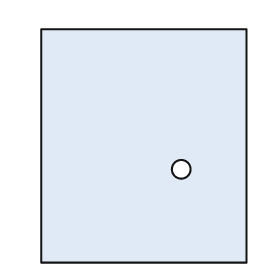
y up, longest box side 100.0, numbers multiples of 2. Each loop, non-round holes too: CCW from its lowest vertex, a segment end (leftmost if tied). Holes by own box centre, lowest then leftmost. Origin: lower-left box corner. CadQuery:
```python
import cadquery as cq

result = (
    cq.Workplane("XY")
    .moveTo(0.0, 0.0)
    .lineTo(88.0, 0.0)
    .lineTo(88.0, 100.0)
    .lineTo(0.0, 100.0)
    .close()
    .moveTo(60.0, 40.0)
    .circle(4.0)
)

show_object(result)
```